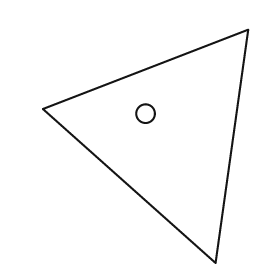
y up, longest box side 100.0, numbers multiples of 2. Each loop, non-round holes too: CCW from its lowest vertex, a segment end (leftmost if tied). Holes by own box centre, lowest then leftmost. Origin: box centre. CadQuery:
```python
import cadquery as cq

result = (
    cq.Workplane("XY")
    .moveTo(30.0, -50.0)
    .lineTo(44.0, 50.0)
    .lineTo(-44.0, 16.0)
    .close()
    .moveTo(0.0, 14.0)
    .circle(4.0)
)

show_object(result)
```